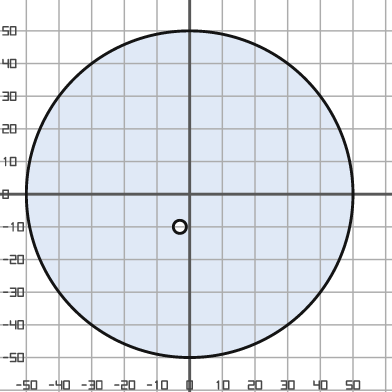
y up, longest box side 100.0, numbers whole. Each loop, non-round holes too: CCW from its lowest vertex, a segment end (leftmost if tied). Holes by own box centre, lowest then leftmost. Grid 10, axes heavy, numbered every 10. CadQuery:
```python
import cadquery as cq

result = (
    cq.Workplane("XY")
    .moveTo(0.0, 0.0)
    .circle(50.0)
    .moveTo(-3.0, -10.0)
    .circle(2.0)
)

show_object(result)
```